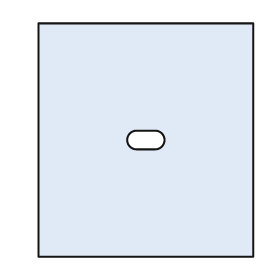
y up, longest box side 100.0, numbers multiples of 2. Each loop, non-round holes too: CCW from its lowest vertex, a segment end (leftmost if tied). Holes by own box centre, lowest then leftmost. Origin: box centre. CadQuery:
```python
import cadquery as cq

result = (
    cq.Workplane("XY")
    .moveTo(-46.0, -50.0)
    .lineTo(46.0, -50.0)
    .lineTo(46.0, 50.0)
    .lineTo(-46.0, 50.0)
    .close()
    .moveTo(-4.0, -4.0)
    .lineTo(4.0, -4.0)
    .threePointArc((8.0, 0.0), (4.0, 4.0))
    .lineTo(-4.0, 4.0)
    .threePointArc((-8.0, 0.0), (-4.0, -4.0))
    .close()
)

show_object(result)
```